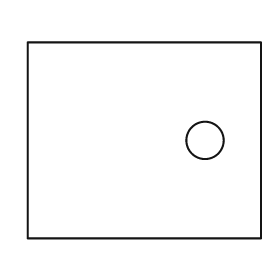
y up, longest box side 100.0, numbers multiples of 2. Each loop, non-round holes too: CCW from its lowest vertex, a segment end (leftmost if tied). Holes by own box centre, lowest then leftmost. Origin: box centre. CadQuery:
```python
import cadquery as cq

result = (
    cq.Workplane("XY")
    .moveTo(-50.0, -42.0)
    .lineTo(50.0, -42.0)
    .lineTo(50.0, 42.0)
    .lineTo(-50.0, 42.0)
    .close()
    .moveTo(26.0, 0.0)
    .circle(8.0)
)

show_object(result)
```